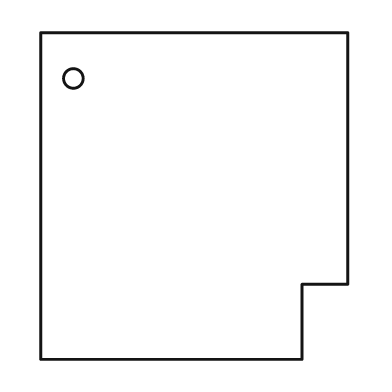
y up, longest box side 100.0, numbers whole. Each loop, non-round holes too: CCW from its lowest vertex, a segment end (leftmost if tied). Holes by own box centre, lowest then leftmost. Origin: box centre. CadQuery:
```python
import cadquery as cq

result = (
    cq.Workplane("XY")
    .moveTo(-47.0, -50.0)
    .lineTo(33.0, -50.0)
    .lineTo(33.0, -27.0)
    .lineTo(47.0, -27.0)
    .lineTo(47.0, 50.0)
    .lineTo(-47.0, 50.0)
    .close()
    .moveTo(-37.0, 36.0)
    .circle(3.0)
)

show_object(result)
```